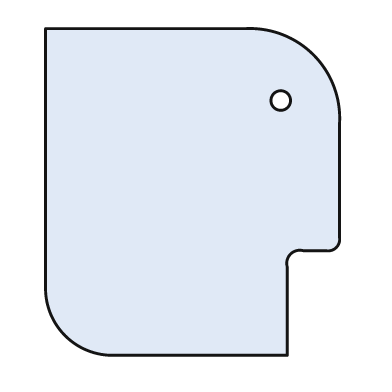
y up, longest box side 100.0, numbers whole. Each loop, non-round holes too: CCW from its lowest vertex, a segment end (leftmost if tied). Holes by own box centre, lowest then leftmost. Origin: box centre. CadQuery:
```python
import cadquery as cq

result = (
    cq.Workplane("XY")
    .moveTo(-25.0, -50.0)
    .lineTo(29.0, -50.0)
    .lineTo(29.0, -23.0)
    .threePointArc((30.0, -19.0), (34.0, -18.0))
    .lineTo(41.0, -18.0)
    .threePointArc((44.0, -17.0), (45.0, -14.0))
    .lineTo(45.0, 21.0)
    .threePointArc((37.0, 42.0), (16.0, 50.0))
    .lineTo(-45.0, 50.0)
    .lineTo(-45.0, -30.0)
    .threePointArc((-39.0, -44.0), (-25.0, -50.0))
    .close()
    .moveTo(27.0, 28.0)
    .circle(3.0)
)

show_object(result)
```